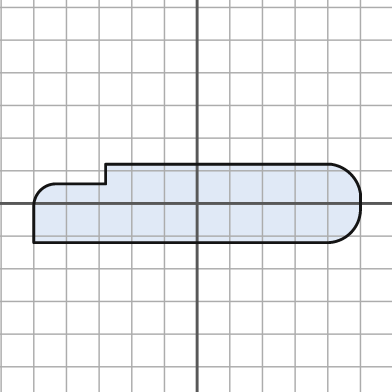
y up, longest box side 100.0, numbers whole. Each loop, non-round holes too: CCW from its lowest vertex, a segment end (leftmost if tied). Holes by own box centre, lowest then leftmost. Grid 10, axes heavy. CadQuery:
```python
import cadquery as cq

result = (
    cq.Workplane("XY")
    .moveTo(-50.0, -12.0)
    .lineTo(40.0, -12.0)
    .threePointArc((47.0, -9.0), (50.0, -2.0))
    .lineTo(50.0, 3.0)
    .threePointArc((47.0, 9.0), (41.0, 12.0))
    .lineTo(-28.0, 12.0)
    .lineTo(-28.0, 6.0)
    .lineTo(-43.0, 6.0)
    .threePointArc((-48.0, 4.0), (-50.0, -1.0))
    .close()
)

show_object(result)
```